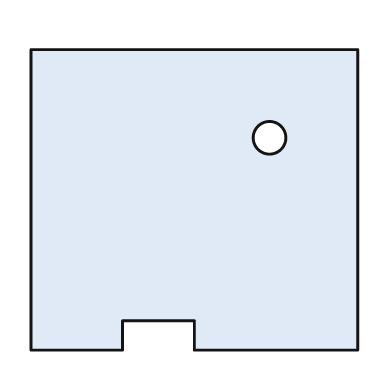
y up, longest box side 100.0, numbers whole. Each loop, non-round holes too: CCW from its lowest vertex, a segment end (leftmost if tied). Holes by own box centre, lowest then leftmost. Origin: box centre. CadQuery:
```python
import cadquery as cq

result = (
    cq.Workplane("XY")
    .moveTo(-50.0, -46.0)
    .lineTo(-22.0, -46.0)
    .lineTo(-22.0, -37.0)
    .lineTo(0.0, -37.0)
    .lineTo(0.0, -46.0)
    .lineTo(50.0, -46.0)
    .lineTo(50.0, 46.0)
    .lineTo(-50.0, 46.0)
    .close()
    .moveTo(23.0, 19.0)
    .circle(5.0)
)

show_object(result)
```